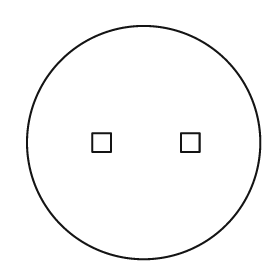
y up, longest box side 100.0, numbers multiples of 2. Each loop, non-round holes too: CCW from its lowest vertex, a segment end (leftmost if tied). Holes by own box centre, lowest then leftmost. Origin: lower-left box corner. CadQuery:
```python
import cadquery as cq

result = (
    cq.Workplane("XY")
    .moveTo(50.0, 50.0)
    .circle(50.0)
    .moveTo(28.0, 46.0)
    .lineTo(36.0, 46.0)
    .lineTo(36.0, 54.0)
    .lineTo(28.0, 54.0)
    .close()
    .moveTo(66.0, 46.0)
    .lineTo(74.0, 46.0)
    .lineTo(74.0, 54.0)
    .lineTo(66.0, 54.0)
    .close()
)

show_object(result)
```